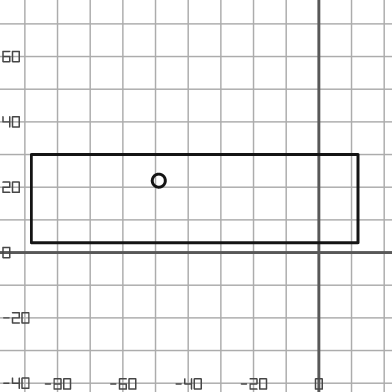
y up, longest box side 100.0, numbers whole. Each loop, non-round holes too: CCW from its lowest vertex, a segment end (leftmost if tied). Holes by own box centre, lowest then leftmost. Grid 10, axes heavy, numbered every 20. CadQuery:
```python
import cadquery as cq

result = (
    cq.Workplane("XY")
    .moveTo(-88.0, 3.0)
    .lineTo(12.0, 3.0)
    .lineTo(12.0, 30.0)
    .lineTo(-88.0, 30.0)
    .close()
    .moveTo(-49.0, 22.0)
    .circle(2.0)
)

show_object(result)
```